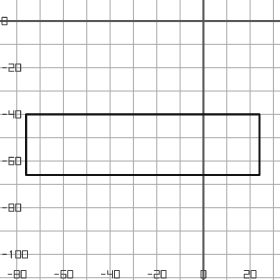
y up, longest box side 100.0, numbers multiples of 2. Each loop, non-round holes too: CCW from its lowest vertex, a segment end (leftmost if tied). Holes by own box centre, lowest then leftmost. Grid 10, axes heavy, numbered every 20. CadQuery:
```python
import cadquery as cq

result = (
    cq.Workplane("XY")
    .moveTo(-76.0, -66.0)
    .lineTo(24.0, -66.0)
    .lineTo(24.0, -40.0)
    .lineTo(-76.0, -40.0)
    .close()
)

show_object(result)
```